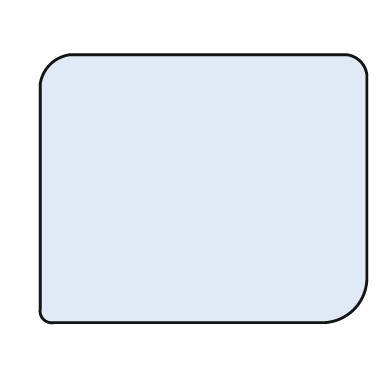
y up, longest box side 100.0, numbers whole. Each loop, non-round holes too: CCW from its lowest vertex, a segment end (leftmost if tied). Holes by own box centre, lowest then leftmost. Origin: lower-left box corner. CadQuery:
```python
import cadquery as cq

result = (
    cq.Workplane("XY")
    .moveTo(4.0, 0.0)
    .lineTo(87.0, 0.0)
    .threePointArc((96.0, 4.0), (100.0, 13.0))
    .lineTo(100.0, 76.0)
    .threePointArc((98.0, 80.0), (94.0, 82.0))
    .lineTo(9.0, 82.0)
    .threePointArc((3.0, 79.0), (0.0, 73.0))
    .lineTo(0.0, 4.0)
    .threePointArc((1.0, 1.0), (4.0, 0.0))
    .close()
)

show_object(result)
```